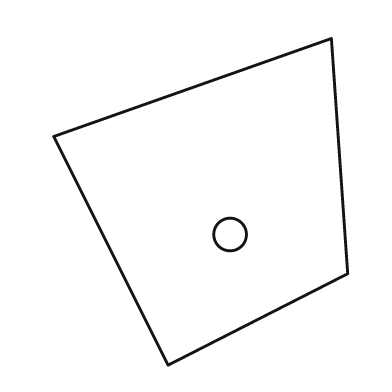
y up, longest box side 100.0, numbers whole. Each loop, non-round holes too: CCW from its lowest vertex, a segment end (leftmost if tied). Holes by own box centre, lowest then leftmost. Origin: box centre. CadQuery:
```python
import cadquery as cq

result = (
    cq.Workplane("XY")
    .moveTo(-10.0, -50.0)
    .lineTo(45.0, -22.0)
    .lineTo(40.0, 50.0)
    .lineTo(-45.0, 20.0)
    .close()
    .moveTo(9.0, -10.0)
    .circle(5.0)
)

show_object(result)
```